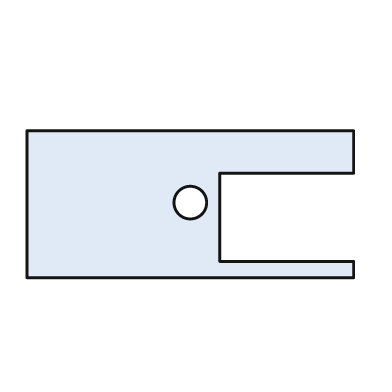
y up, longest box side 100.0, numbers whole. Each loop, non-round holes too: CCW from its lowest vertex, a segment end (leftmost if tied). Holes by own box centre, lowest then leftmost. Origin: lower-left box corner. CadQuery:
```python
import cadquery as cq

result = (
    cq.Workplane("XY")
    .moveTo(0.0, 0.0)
    .lineTo(100.0, 0.0)
    .lineTo(100.0, 5.0)
    .lineTo(59.0, 5.0)
    .lineTo(59.0, 32.0)
    .lineTo(100.0, 32.0)
    .lineTo(100.0, 45.0)
    .lineTo(0.0, 45.0)
    .close()
    .moveTo(50.0, 23.0)
    .circle(5.0)
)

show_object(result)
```